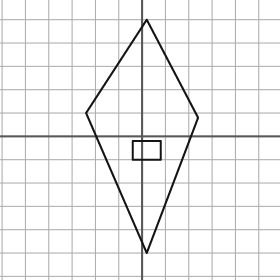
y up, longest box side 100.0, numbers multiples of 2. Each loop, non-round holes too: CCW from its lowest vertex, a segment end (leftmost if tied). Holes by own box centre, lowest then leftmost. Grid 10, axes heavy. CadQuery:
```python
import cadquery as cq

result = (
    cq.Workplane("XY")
    .moveTo(2.0, -50.0)
    .lineTo(24.0, 8.0)
    .lineTo(2.0, 50.0)
    .lineTo(-24.0, 10.0)
    .close()
    .moveTo(-4.0, -10.0)
    .lineTo(8.0, -10.0)
    .lineTo(8.0, -2.0)
    .lineTo(-4.0, -2.0)
    .close()
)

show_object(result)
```